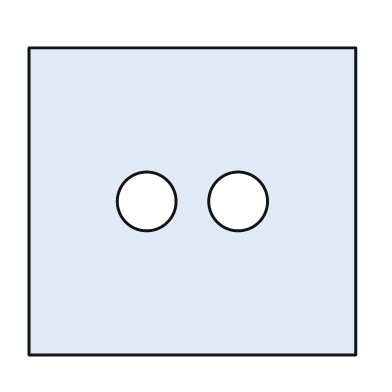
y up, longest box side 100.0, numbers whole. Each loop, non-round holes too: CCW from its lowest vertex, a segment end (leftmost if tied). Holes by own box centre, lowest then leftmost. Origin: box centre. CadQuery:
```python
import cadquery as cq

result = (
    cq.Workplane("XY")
    .moveTo(-50.0, -47.0)
    .lineTo(50.0, -47.0)
    .lineTo(50.0, 47.0)
    .lineTo(-50.0, 47.0)
    .close()
    .moveTo(-14.0, 0.0)
    .circle(9.0)
    .moveTo(14.0, 0.0)
    .circle(9.0)
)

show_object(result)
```